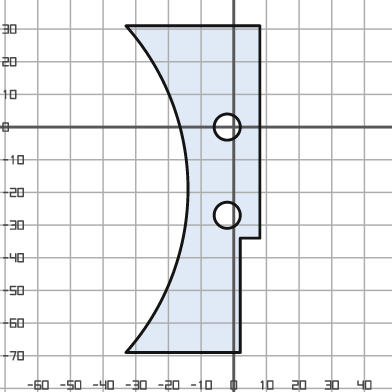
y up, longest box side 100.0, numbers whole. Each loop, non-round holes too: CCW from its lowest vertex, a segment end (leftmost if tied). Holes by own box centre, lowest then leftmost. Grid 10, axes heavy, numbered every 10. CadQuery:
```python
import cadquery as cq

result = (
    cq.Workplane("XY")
    .moveTo(-33.0, -69.0)
    .lineTo(2.0, -69.0)
    .lineTo(2.0, -34.0)
    .lineTo(8.0, -34.0)
    .lineTo(8.0, 31.0)
    .lineTo(-33.0, 31.0)
    .threePointArc((-14.0, -19.0), (-33.0, -69.0))
    .close()
    .moveTo(-2.0, -27.0)
    .circle(4.0)
    .moveTo(-2.0, 0.0)
    .circle(4.0)
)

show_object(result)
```